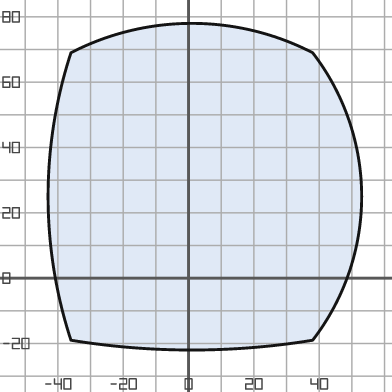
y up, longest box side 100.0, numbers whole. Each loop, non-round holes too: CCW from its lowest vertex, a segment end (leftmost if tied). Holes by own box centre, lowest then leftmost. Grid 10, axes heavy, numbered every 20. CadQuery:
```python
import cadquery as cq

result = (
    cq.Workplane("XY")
    .moveTo(-36.0, -19.0)
    .threePointArc((1.0, -22.0), (38.0, -19.0))
    .threePointArc((53.0, 25.0), (38.0, 69.0))
    .threePointArc((1.0, 78.0), (-36.0, 69.0))
    .threePointArc((-43.0, 25.0), (-36.0, -19.0))
    .close()
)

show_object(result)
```